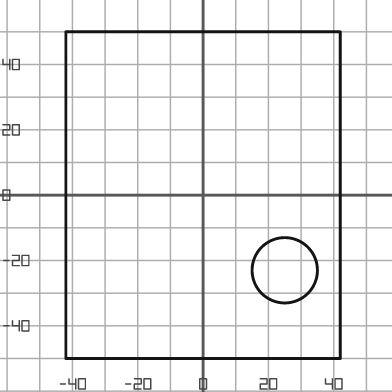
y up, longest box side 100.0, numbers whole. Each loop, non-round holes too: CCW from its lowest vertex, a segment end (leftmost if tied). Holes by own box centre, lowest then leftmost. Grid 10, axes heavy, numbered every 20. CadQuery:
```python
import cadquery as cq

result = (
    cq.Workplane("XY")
    .moveTo(-42.0, -50.0)
    .lineTo(42.0, -50.0)
    .lineTo(42.0, 50.0)
    .lineTo(-42.0, 50.0)
    .close()
    .moveTo(25.0, -23.0)
    .circle(10.0)
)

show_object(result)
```